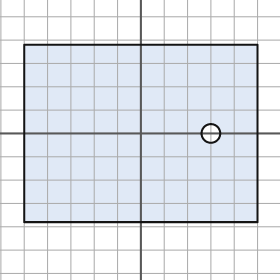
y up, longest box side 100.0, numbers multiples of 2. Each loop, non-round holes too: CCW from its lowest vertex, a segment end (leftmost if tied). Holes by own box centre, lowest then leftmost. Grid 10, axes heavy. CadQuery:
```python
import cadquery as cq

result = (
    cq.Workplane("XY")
    .moveTo(-50.0, -38.0)
    .lineTo(50.0, -38.0)
    .lineTo(50.0, 38.0)
    .lineTo(-50.0, 38.0)
    .close()
    .moveTo(30.0, 0.0)
    .circle(4.0)
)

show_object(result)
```